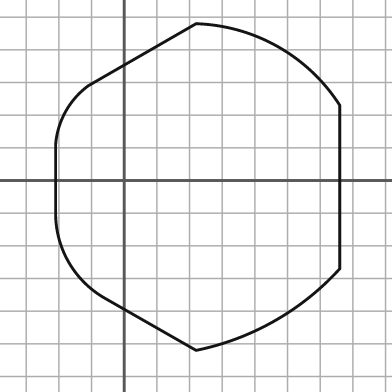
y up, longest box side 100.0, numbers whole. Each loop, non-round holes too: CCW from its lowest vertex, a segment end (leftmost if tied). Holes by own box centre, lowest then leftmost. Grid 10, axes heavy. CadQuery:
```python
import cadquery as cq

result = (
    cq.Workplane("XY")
    .moveTo(22.0, -52.0)
    .threePointArc((46.0, -43.0), (66.0, -27.0))
    .lineTo(66.0, 23.0)
    .threePointArc((47.0, 41.0), (22.0, 48.0))
    .lineTo(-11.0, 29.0)
    .threePointArc((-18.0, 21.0), (-21.0, 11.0))
    .lineTo(-21.0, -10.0)
    .threePointArc((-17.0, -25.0), (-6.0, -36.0))
    .close()
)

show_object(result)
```